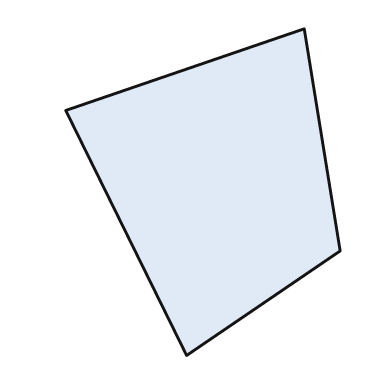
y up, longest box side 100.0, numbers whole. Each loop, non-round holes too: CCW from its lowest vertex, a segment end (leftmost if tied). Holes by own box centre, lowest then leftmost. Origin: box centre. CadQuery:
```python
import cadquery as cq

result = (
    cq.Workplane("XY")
    .moveTo(-5.0, -50.0)
    .lineTo(42.0, -18.0)
    .lineTo(31.0, 50.0)
    .lineTo(-42.0, 25.0)
    .close()
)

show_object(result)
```